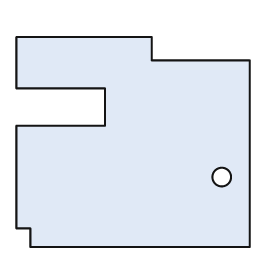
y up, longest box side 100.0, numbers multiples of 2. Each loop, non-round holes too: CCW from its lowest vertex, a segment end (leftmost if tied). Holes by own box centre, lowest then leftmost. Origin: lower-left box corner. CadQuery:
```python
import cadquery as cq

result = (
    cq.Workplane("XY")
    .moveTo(6.0, 0.0)
    .lineTo(100.0, 0.0)
    .lineTo(100.0, 80.0)
    .lineTo(58.0, 80.0)
    .lineTo(58.0, 90.0)
    .lineTo(0.0, 90.0)
    .lineTo(0.0, 68.0)
    .lineTo(38.0, 68.0)
    .lineTo(38.0, 52.0)
    .lineTo(0.0, 52.0)
    .lineTo(0.0, 8.0)
    .lineTo(6.0, 8.0)
    .close()
    .moveTo(88.0, 30.0)
    .circle(4.0)
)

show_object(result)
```